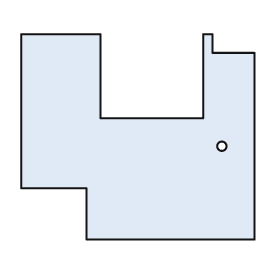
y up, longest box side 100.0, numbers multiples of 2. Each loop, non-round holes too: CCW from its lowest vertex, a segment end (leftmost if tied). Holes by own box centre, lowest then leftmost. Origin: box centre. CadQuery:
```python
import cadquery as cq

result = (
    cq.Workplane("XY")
    .moveTo(-22.0, -44.0)
    .lineTo(50.0, -44.0)
    .lineTo(50.0, 36.0)
    .lineTo(32.0, 36.0)
    .lineTo(32.0, 44.0)
    .lineTo(28.0, 44.0)
    .lineTo(28.0, 8.0)
    .lineTo(-16.0, 8.0)
    .lineTo(-16.0, 44.0)
    .lineTo(-50.0, 44.0)
    .lineTo(-50.0, -22.0)
    .lineTo(-22.0, -22.0)
    .close()
    .moveTo(36.0, -4.0)
    .circle(2.0)
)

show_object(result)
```